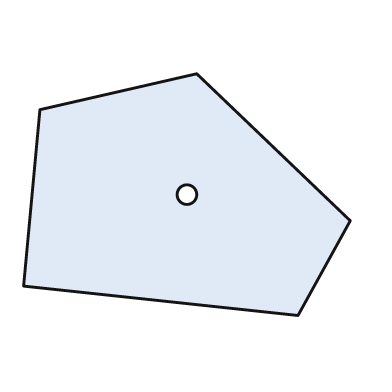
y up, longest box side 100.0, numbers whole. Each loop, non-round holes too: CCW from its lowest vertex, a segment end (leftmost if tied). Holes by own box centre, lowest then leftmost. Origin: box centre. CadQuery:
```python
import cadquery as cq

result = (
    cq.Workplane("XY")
    .moveTo(34.0, -37.0)
    .lineTo(50.0, -8.0)
    .lineTo(3.0, 37.0)
    .lineTo(-45.0, 26.0)
    .lineTo(-50.0, -28.0)
    .close()
    .moveTo(0.0, 0.0)
    .circle(3.0)
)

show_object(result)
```